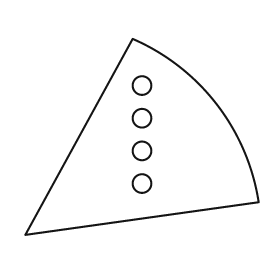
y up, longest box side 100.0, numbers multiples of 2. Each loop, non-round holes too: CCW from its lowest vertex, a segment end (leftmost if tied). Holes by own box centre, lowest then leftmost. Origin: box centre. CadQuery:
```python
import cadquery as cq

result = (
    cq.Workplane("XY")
    .moveTo(-50.0, -42.0)
    .lineTo(50.0, -28.0)
    .threePointArc((32.0, 14.0), (-4.0, 42.0))
    .close()
    .moveTo(0.0, -20.0)
    .circle(4.0)
    .moveTo(0.0, -6.0)
    .circle(4.0)
    .moveTo(0.0, 8.0)
    .circle(4.0)
    .moveTo(0.0, 22.0)
    .circle(4.0)
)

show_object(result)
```